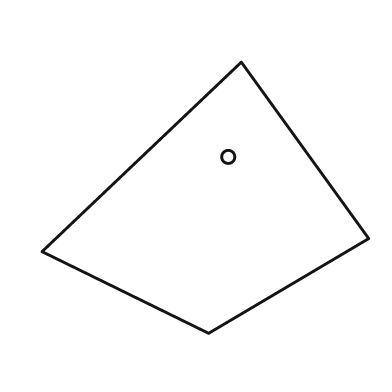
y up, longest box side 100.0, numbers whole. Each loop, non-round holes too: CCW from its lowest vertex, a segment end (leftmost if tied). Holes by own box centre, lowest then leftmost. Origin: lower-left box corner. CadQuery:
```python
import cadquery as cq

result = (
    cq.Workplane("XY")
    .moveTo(51.0, 0.0)
    .lineTo(100.0, 29.0)
    .lineTo(61.0, 83.0)
    .lineTo(0.0, 25.0)
    .close()
    .moveTo(57.0, 54.0)
    .circle(2.0)
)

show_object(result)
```